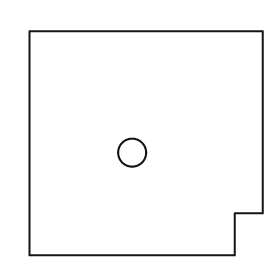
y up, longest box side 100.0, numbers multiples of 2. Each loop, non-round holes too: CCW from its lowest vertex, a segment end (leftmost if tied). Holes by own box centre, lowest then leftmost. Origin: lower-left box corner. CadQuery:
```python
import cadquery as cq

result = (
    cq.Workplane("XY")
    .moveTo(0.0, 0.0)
    .lineTo(88.0, 0.0)
    .lineTo(88.0, 18.0)
    .lineTo(100.0, 18.0)
    .lineTo(100.0, 96.0)
    .lineTo(0.0, 96.0)
    .close()
    .moveTo(44.0, 44.0)
    .circle(6.0)
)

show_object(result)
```